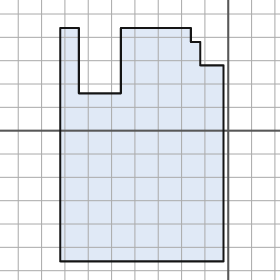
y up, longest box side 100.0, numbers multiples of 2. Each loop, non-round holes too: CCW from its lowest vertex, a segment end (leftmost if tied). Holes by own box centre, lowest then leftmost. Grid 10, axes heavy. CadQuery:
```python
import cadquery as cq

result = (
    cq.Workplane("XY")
    .moveTo(-72.0, -56.0)
    .lineTo(-2.0, -56.0)
    .lineTo(-2.0, 28.0)
    .lineTo(-12.0, 28.0)
    .lineTo(-12.0, 38.0)
    .lineTo(-16.0, 38.0)
    .lineTo(-16.0, 44.0)
    .lineTo(-46.0, 44.0)
    .lineTo(-46.0, 16.0)
    .lineTo(-64.0, 16.0)
    .lineTo(-64.0, 44.0)
    .lineTo(-72.0, 44.0)
    .close()
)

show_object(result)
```